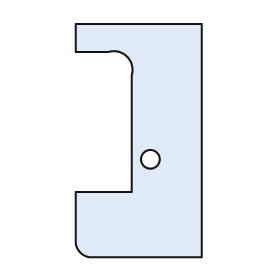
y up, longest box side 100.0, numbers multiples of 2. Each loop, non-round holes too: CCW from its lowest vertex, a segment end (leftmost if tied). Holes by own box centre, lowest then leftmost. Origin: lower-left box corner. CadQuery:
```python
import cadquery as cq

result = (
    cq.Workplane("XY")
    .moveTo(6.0, 0.0)
    .lineTo(54.0, 0.0)
    .lineTo(54.0, 100.0)
    .lineTo(0.0, 100.0)
    .lineTo(0.0, 88.0)
    .lineTo(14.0, 88.0)
    .threePointArc((22.0, 86.0), (24.0, 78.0))
    .lineTo(24.0, 28.0)
    .lineTo(0.0, 28.0)
    .lineTo(0.0, 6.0)
    .threePointArc((2.0, 2.0), (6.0, 0.0))
    .close()
    .moveTo(32.0, 42.0)
    .circle(4.0)
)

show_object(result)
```